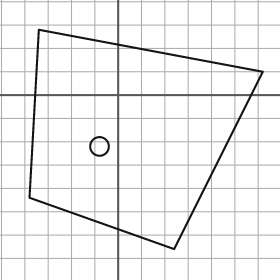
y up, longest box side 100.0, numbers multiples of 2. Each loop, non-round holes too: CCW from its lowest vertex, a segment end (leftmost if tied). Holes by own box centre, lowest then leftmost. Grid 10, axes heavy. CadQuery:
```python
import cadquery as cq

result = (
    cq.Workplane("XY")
    .moveTo(24.0, -66.0)
    .lineTo(62.0, 10.0)
    .lineTo(-34.0, 28.0)
    .lineTo(-38.0, -44.0)
    .close()
    .moveTo(-8.0, -22.0)
    .circle(4.0)
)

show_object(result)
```